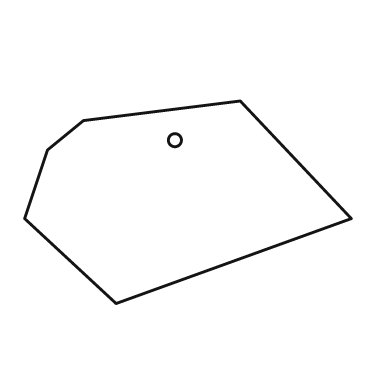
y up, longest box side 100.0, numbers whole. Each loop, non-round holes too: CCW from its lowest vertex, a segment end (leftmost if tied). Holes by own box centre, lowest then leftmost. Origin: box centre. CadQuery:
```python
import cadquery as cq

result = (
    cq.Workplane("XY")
    .moveTo(-22.0, -31.0)
    .lineTo(50.0, -5.0)
    .lineTo(16.0, 31.0)
    .lineTo(-32.0, 25.0)
    .lineTo(-43.0, 16.0)
    .lineTo(-50.0, -5.0)
    .close()
    .moveTo(-4.0, 19.0)
    .circle(2.0)
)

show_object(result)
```